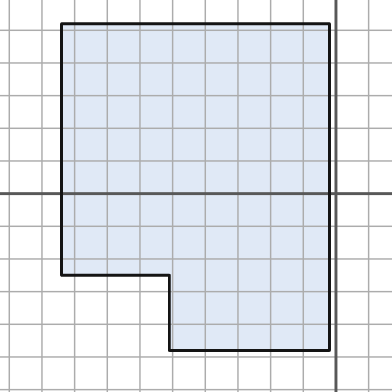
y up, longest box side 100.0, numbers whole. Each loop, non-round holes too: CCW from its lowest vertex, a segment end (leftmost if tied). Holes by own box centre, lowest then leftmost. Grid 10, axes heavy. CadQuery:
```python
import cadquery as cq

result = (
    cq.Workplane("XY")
    .moveTo(-51.0, -48.0)
    .lineTo(-2.0, -48.0)
    .lineTo(-2.0, 52.0)
    .lineTo(-84.0, 52.0)
    .lineTo(-84.0, -25.0)
    .lineTo(-51.0, -25.0)
    .close()
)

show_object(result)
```